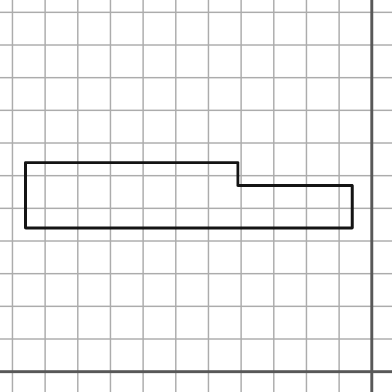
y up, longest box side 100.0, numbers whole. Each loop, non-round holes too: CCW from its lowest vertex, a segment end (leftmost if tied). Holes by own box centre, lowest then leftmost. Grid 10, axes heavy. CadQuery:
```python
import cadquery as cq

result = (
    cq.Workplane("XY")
    .moveTo(-106.0, 44.0)
    .lineTo(-6.0, 44.0)
    .lineTo(-6.0, 57.0)
    .lineTo(-41.0, 57.0)
    .lineTo(-41.0, 64.0)
    .lineTo(-106.0, 64.0)
    .close()
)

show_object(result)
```